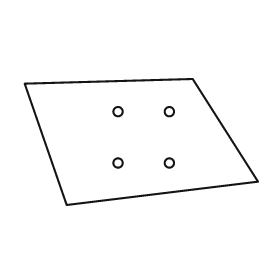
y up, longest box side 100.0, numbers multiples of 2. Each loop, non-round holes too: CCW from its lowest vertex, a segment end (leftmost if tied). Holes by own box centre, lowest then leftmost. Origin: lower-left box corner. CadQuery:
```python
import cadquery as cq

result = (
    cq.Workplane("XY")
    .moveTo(18.0, 0.0)
    .lineTo(100.0, 10.0)
    .lineTo(72.0, 54.0)
    .lineTo(0.0, 52.0)
    .close()
    .moveTo(40.0, 18.0)
    .circle(2.0)
    .moveTo(62.0, 18.0)
    .circle(2.0)
    .moveTo(40.0, 40.0)
    .circle(2.0)
    .moveTo(62.0, 40.0)
    .circle(2.0)
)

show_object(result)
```